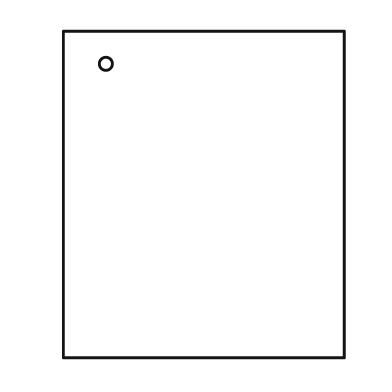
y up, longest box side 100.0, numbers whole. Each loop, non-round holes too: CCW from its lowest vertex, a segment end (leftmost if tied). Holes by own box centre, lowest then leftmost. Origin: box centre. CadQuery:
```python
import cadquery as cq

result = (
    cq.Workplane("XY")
    .moveTo(-43.0, -50.0)
    .lineTo(43.0, -50.0)
    .lineTo(43.0, 50.0)
    .lineTo(-43.0, 50.0)
    .close()
    .moveTo(-30.0, 40.0)
    .circle(2.0)
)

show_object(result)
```